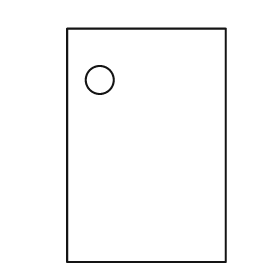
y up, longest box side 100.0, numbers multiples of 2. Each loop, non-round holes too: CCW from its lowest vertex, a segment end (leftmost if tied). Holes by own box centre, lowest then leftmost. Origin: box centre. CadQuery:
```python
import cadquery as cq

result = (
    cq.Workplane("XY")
    .moveTo(-34.0, -50.0)
    .lineTo(34.0, -50.0)
    .lineTo(34.0, 50.0)
    .lineTo(-34.0, 50.0)
    .close()
    .moveTo(-20.0, 28.0)
    .circle(6.0)
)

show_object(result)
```